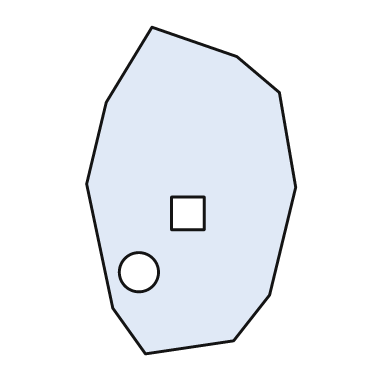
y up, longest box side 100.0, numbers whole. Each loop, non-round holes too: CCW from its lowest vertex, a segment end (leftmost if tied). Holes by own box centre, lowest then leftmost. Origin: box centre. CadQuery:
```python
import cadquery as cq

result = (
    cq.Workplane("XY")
    .moveTo(-14.0, -50.0)
    .lineTo(13.0, -46.0)
    .lineTo(24.0, -32.0)
    .lineTo(32.0, 1.0)
    .lineTo(27.0, 30.0)
    .lineTo(14.0, 41.0)
    .lineTo(-12.0, 50.0)
    .lineTo(-26.0, 27.0)
    .lineTo(-32.0, 2.0)
    .lineTo(-24.0, -36.0)
    .close()
    .moveTo(-16.0, -25.0)
    .circle(6.0)
    .moveTo(-6.0, -12.0)
    .lineTo(4.0, -12.0)
    .lineTo(4.0, -2.0)
    .lineTo(-6.0, -2.0)
    .close()
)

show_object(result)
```